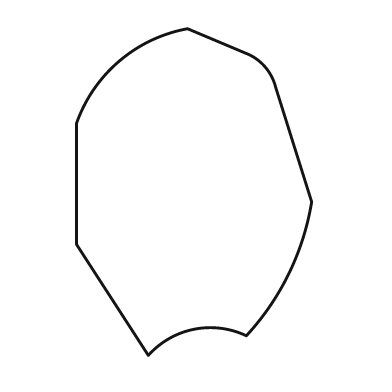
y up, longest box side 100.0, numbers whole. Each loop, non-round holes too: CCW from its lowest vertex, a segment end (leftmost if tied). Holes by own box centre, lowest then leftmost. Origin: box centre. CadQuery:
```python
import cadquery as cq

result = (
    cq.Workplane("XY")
    .moveTo(-14.0, -50.0)
    .threePointArc((0.0, -42.0), (16.0, -44.0))
    .threePointArc((29.0, -25.0), (36.0, -3.0))
    .lineTo(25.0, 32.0)
    .threePointArc((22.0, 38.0), (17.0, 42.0))
    .lineTo(-2.0, 50.0)
    .threePointArc((-23.0, 40.0), (-36.0, 21.0))
    .lineTo(-36.0, -16.0)
    .close()
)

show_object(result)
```